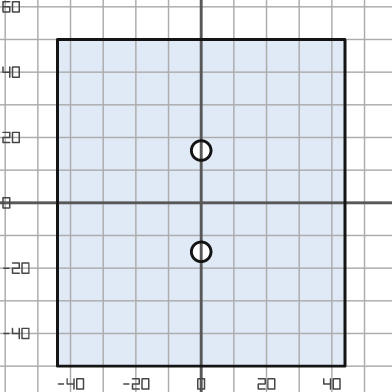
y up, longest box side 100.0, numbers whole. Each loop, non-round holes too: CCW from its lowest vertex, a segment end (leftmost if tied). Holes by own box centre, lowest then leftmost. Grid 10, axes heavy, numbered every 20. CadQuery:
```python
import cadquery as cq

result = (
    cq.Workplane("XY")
    .moveTo(-44.0, -50.0)
    .lineTo(44.0, -50.0)
    .lineTo(44.0, 50.0)
    .lineTo(-44.0, 50.0)
    .close()
    .moveTo(0.0, -15.0)
    .circle(3.0)
    .moveTo(0.0, 16.0)
    .circle(3.0)
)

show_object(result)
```